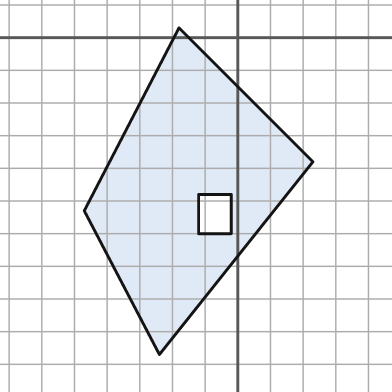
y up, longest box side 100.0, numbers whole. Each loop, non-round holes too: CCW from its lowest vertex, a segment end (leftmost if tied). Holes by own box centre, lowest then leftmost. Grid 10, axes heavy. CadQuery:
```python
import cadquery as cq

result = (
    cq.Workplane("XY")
    .moveTo(-24.0, -97.0)
    .lineTo(23.0, -38.0)
    .lineTo(-18.0, 3.0)
    .lineTo(-47.0, -53.0)
    .close()
    .moveTo(-12.0, -60.0)
    .lineTo(-2.0, -60.0)
    .lineTo(-2.0, -48.0)
    .lineTo(-12.0, -48.0)
    .close()
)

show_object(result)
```